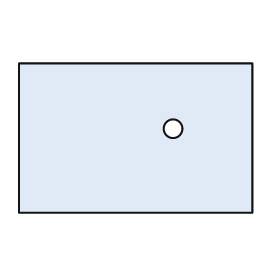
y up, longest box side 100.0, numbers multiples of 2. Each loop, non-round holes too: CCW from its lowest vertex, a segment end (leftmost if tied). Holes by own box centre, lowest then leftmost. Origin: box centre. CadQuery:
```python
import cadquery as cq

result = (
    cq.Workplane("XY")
    .moveTo(-50.0, -32.0)
    .lineTo(50.0, -32.0)
    .lineTo(50.0, 32.0)
    .lineTo(-50.0, 32.0)
    .close()
    .moveTo(16.0, 4.0)
    .circle(4.0)
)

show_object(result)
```